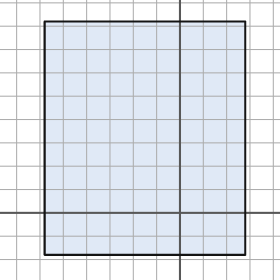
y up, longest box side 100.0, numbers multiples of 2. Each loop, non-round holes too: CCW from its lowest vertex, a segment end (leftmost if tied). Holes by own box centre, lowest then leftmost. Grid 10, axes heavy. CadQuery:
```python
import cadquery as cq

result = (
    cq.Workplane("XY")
    .moveTo(-58.0, -18.0)
    .lineTo(28.0, -18.0)
    .lineTo(28.0, 82.0)
    .lineTo(-58.0, 82.0)
    .close()
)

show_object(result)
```